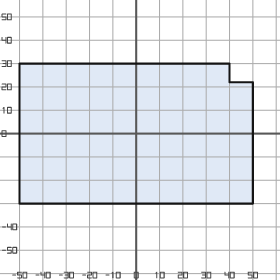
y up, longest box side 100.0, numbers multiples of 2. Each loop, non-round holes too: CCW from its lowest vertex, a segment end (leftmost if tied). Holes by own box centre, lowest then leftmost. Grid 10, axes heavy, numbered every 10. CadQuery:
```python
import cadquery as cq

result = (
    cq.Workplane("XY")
    .moveTo(-50.0, -30.0)
    .lineTo(50.0, -30.0)
    .lineTo(50.0, 22.0)
    .lineTo(40.0, 22.0)
    .lineTo(40.0, 30.0)
    .lineTo(-50.0, 30.0)
    .close()
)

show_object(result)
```